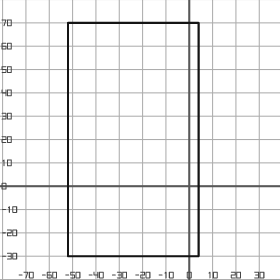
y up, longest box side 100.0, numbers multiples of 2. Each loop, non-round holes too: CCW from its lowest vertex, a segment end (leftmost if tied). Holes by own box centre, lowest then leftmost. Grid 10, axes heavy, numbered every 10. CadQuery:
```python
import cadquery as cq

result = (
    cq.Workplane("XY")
    .moveTo(-52.0, -30.0)
    .lineTo(4.0, -30.0)
    .lineTo(4.0, 70.0)
    .lineTo(-52.0, 70.0)
    .close()
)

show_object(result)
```